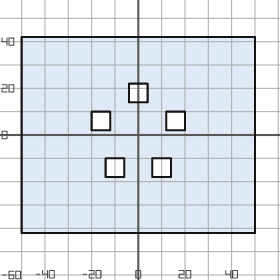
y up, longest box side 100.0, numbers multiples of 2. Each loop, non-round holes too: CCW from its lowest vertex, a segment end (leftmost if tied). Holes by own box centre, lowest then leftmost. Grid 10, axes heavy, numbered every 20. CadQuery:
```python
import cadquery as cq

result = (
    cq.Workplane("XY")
    .moveTo(-50.0, -42.0)
    .lineTo(50.0, -42.0)
    .lineTo(50.0, 42.0)
    .lineTo(-50.0, 42.0)
    .close()
    .moveTo(-14.0, -18.0)
    .lineTo(-6.0, -18.0)
    .lineTo(-6.0, -10.0)
    .lineTo(-14.0, -10.0)
    .close()
    .moveTo(6.0, -18.0)
    .lineTo(14.0, -18.0)
    .lineTo(14.0, -10.0)
    .lineTo(6.0, -10.0)
    .close()
    .moveTo(-20.0, 2.0)
    .lineTo(-12.0, 2.0)
    .lineTo(-12.0, 10.0)
    .lineTo(-20.0, 10.0)
    .close()
    .moveTo(12.0, 2.0)
    .lineTo(20.0, 2.0)
    .lineTo(20.0, 10.0)
    .lineTo(12.0, 10.0)
    .close()
    .moveTo(-4.0, 14.0)
    .lineTo(4.0, 14.0)
    .lineTo(4.0, 22.0)
    .lineTo(-4.0, 22.0)
    .close()
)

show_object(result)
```